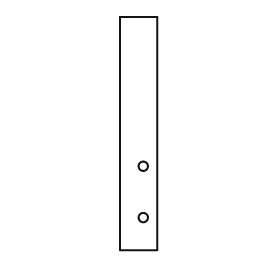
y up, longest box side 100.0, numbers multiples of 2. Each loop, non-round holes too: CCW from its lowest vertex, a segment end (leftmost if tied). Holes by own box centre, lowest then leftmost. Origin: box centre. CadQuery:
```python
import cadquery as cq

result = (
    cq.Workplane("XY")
    .moveTo(-8.0, -50.0)
    .lineTo(8.0, -50.0)
    .lineTo(8.0, 50.0)
    .lineTo(-8.0, 50.0)
    .close()
    .moveTo(2.0, -36.0)
    .circle(2.0)
    .moveTo(2.0, -14.0)
    .circle(2.0)
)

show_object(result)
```